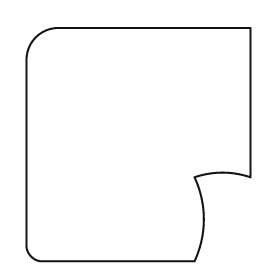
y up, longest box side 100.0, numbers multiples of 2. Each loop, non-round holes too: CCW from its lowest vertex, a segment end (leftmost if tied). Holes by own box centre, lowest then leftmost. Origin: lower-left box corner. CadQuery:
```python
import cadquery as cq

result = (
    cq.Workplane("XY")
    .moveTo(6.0, 0.0)
    .lineTo(72.0, 0.0)
    .threePointArc((76.0, 18.0), (72.0, 36.0))
    .threePointArc((84.0, 38.0), (96.0, 36.0))
    .lineTo(96.0, 100.0)
    .lineTo(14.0, 100.0)
    .threePointArc((4.0, 96.0), (0.0, 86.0))
    .lineTo(0.0, 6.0)
    .threePointArc((2.0, 2.0), (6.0, 0.0))
    .close()
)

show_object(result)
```